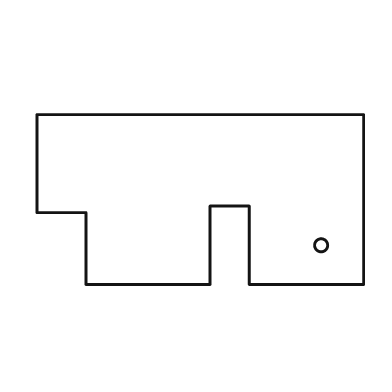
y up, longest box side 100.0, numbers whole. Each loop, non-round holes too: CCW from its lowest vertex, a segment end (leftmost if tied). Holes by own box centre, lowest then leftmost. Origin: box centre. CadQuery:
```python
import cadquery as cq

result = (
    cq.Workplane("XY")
    .moveTo(-35.0, -26.0)
    .lineTo(3.0, -26.0)
    .lineTo(3.0, -2.0)
    .lineTo(15.0, -2.0)
    .lineTo(15.0, -26.0)
    .lineTo(50.0, -26.0)
    .lineTo(50.0, 26.0)
    .lineTo(-50.0, 26.0)
    .lineTo(-50.0, -4.0)
    .lineTo(-35.0, -4.0)
    .close()
    .moveTo(37.0, -14.0)
    .circle(2.0)
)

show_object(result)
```